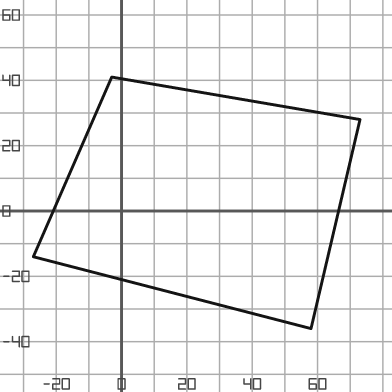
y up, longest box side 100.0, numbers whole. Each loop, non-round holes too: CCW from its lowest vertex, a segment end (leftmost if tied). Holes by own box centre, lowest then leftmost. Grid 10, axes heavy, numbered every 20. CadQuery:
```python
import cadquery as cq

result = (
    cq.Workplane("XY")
    .moveTo(58.0, -36.0)
    .lineTo(73.0, 28.0)
    .lineTo(-3.0, 41.0)
    .lineTo(-27.0, -14.0)
    .close()
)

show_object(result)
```